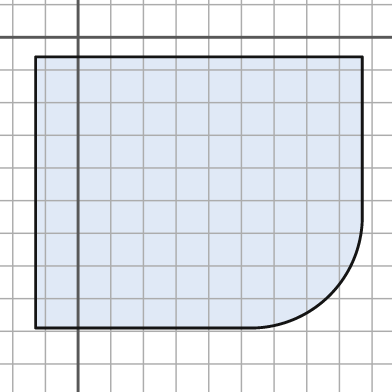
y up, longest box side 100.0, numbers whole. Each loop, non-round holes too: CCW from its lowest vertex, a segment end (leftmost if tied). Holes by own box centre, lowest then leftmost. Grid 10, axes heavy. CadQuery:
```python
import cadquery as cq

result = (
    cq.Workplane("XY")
    .moveTo(-13.0, -89.0)
    .lineTo(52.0, -89.0)
    .threePointArc((77.0, -79.0), (87.0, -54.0))
    .lineTo(87.0, -6.0)
    .lineTo(-13.0, -6.0)
    .close()
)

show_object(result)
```